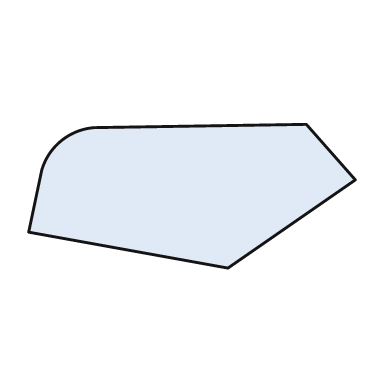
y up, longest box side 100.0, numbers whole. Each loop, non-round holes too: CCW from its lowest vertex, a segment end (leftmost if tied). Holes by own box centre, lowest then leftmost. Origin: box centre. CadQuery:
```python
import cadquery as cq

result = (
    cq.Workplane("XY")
    .moveTo(11.0, -22.0)
    .lineTo(50.0, 5.0)
    .lineTo(35.0, 22.0)
    .lineTo(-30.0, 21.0)
    .threePointArc((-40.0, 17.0), (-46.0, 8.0))
    .lineTo(-50.0, -11.0)
    .close()
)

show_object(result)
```